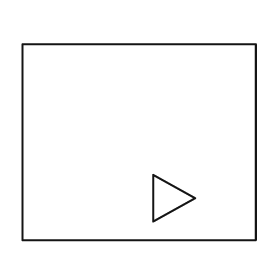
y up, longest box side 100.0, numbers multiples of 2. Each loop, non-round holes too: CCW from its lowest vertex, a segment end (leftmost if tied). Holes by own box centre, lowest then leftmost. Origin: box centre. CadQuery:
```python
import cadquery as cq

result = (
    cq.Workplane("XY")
    .moveTo(-50.0, -42.0)
    .lineTo(50.0, -42.0)
    .lineTo(50.0, 42.0)
    .lineTo(-50.0, 42.0)
    .close()
    .moveTo(6.0, -34.0)
    .lineTo(24.0, -24.0)
    .lineTo(6.0, -14.0)
    .close()
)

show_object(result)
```